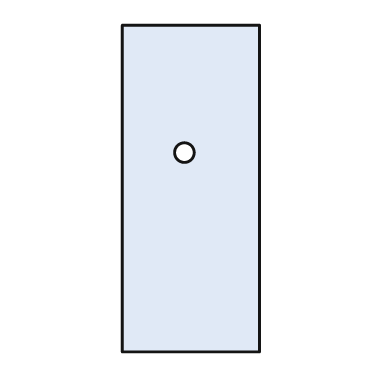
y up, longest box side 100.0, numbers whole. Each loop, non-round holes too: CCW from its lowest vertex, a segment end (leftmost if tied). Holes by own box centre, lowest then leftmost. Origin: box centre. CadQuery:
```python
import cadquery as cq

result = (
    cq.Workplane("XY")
    .moveTo(-21.0, -50.0)
    .lineTo(21.0, -50.0)
    .lineTo(21.0, 50.0)
    .lineTo(-21.0, 50.0)
    .close()
    .moveTo(-2.0, 11.0)
    .circle(3.0)
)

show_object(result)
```